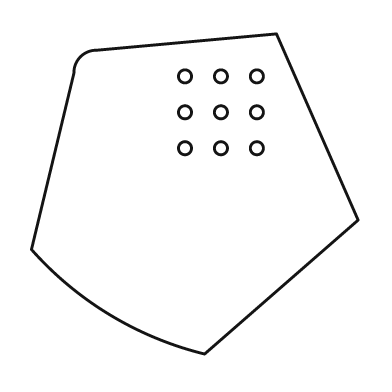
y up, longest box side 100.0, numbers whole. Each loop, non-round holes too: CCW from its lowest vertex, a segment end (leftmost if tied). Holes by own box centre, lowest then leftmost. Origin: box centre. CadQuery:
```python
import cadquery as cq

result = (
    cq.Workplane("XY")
    .moveTo(3.0, -49.0)
    .lineTo(50.0, -8.0)
    .lineTo(25.0, 49.0)
    .lineTo(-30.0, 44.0)
    .threePointArc((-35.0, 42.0), (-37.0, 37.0))
    .lineTo(-50.0, -17.0)
    .threePointArc((-26.0, -37.0), (3.0, -49.0))
    .close()
    .moveTo(-3.0, 14.0)
    .circle(2.0)
    .moveTo(8.0, 14.0)
    .circle(2.0)
    .moveTo(19.0, 14.0)
    .circle(2.0)
    .moveTo(-3.0, 25.0)
    .circle(2.0)
    .moveTo(8.0, 25.0)
    .circle(2.0)
    .moveTo(19.0, 25.0)
    .circle(2.0)
    .moveTo(-3.0, 36.0)
    .circle(2.0)
    .moveTo(8.0, 36.0)
    .circle(2.0)
    .moveTo(19.0, 36.0)
    .circle(2.0)
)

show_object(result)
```